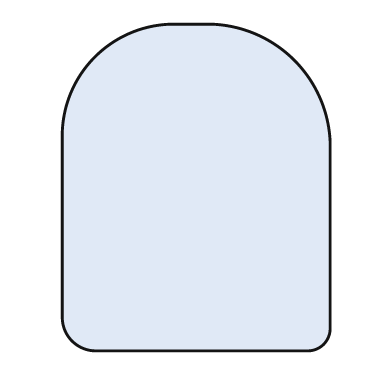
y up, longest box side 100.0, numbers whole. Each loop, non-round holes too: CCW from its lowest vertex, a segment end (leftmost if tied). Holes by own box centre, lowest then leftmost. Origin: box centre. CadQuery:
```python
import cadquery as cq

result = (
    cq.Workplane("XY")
    .moveTo(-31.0, -50.0)
    .lineTo(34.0, -50.0)
    .threePointArc((39.0, -48.0), (41.0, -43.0))
    .lineTo(41.0, 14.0)
    .threePointArc((30.0, 39.0), (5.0, 50.0))
    .lineTo(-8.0, 50.0)
    .threePointArc((-31.0, 40.0), (-41.0, 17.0))
    .lineTo(-41.0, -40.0)
    .threePointArc((-38.0, -47.0), (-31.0, -50.0))
    .close()
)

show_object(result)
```